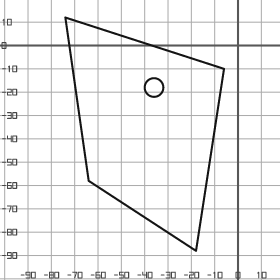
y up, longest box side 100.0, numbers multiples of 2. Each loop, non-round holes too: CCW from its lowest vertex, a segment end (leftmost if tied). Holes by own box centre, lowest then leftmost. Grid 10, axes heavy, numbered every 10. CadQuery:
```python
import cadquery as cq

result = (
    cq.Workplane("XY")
    .moveTo(-18.0, -88.0)
    .lineTo(-6.0, -10.0)
    .lineTo(-74.0, 12.0)
    .lineTo(-64.0, -58.0)
    .close()
    .moveTo(-36.0, -18.0)
    .circle(4.0)
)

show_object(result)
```